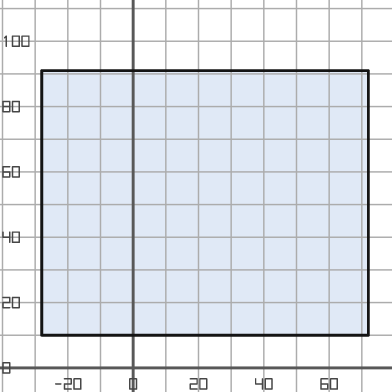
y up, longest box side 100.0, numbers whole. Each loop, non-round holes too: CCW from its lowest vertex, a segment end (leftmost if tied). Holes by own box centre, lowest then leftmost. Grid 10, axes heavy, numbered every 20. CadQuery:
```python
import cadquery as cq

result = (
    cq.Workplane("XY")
    .moveTo(-28.0, 10.0)
    .lineTo(72.0, 10.0)
    .lineTo(72.0, 91.0)
    .lineTo(-28.0, 91.0)
    .close()
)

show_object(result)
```